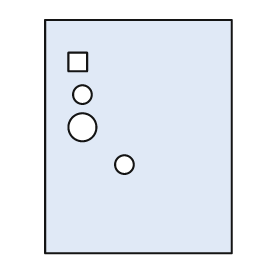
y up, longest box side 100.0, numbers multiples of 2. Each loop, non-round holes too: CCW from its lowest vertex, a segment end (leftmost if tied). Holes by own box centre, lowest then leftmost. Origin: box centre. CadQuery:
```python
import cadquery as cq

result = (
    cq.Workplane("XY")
    .moveTo(-40.0, -50.0)
    .lineTo(40.0, -50.0)
    .lineTo(40.0, 50.0)
    .lineTo(-40.0, 50.0)
    .close()
    .moveTo(-6.0, -12.0)
    .circle(4.0)
    .moveTo(-24.0, 4.0)
    .circle(6.0)
    .moveTo(-24.0, 18.0)
    .circle(4.0)
    .moveTo(-30.0, 28.0)
    .lineTo(-22.0, 28.0)
    .lineTo(-22.0, 36.0)
    .lineTo(-30.0, 36.0)
    .close()
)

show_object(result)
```